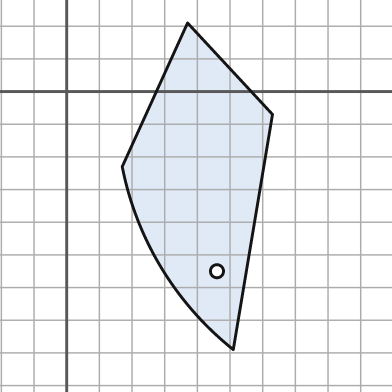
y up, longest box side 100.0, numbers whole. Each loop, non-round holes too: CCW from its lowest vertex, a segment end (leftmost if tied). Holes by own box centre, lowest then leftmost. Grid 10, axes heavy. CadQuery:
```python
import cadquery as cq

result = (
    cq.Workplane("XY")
    .moveTo(51.0, -79.0)
    .lineTo(63.0, -7.0)
    .lineTo(37.0, 21.0)
    .lineTo(17.0, -23.0)
    .threePointArc((29.0, -54.0), (51.0, -79.0))
    .close()
    .moveTo(46.0, -55.0)
    .circle(2.0)
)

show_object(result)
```